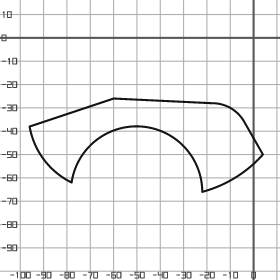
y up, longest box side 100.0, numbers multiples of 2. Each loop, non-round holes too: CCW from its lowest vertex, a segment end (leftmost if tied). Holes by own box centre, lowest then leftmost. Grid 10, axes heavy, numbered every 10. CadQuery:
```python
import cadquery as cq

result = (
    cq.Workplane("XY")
    .moveTo(-22.0, -66.0)
    .threePointArc((-8.0, -60.0), (4.0, -50.0))
    .lineTo(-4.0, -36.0)
    .threePointArc((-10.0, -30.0), (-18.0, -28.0))
    .lineTo(-60.0, -26.0)
    .lineTo(-96.0, -38.0)
    .threePointArc((-90.0, -52.0), (-78.0, -62.0))
    .threePointArc((-48.0, -38.0), (-22.0, -66.0))
    .close()
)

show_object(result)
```